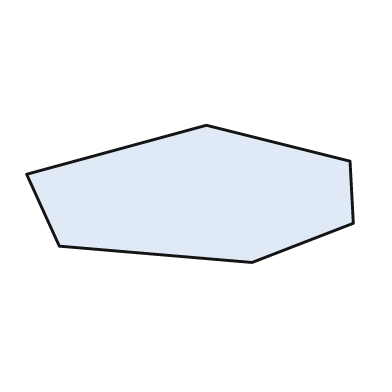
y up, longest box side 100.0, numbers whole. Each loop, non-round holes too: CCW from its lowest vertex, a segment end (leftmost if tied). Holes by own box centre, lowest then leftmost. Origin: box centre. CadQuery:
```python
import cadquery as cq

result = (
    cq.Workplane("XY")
    .moveTo(19.0, -21.0)
    .lineTo(50.0, -9.0)
    .lineTo(49.0, 10.0)
    .lineTo(5.0, 21.0)
    .lineTo(-50.0, 6.0)
    .lineTo(-40.0, -16.0)
    .close()
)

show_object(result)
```